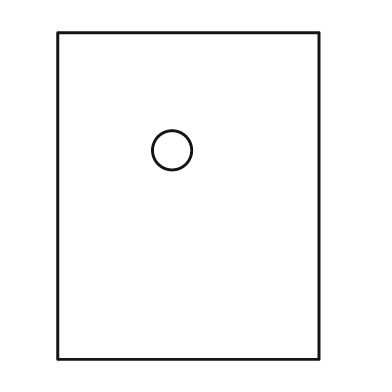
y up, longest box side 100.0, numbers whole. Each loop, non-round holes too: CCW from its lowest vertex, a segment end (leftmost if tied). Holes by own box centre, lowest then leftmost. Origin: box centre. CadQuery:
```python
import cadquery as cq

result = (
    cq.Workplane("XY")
    .moveTo(-40.0, -50.0)
    .lineTo(40.0, -50.0)
    .lineTo(40.0, 50.0)
    .lineTo(-40.0, 50.0)
    .close()
    .moveTo(-5.0, 14.0)
    .circle(6.0)
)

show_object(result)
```